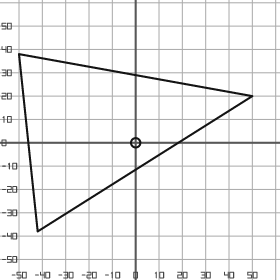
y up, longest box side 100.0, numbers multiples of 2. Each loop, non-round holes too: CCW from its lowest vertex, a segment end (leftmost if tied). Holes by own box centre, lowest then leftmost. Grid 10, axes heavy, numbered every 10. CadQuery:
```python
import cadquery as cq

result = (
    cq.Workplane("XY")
    .moveTo(-42.0, -38.0)
    .lineTo(50.0, 20.0)
    .lineTo(-50.0, 38.0)
    .close()
    .moveTo(0.0, 0.0)
    .circle(2.0)
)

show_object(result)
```